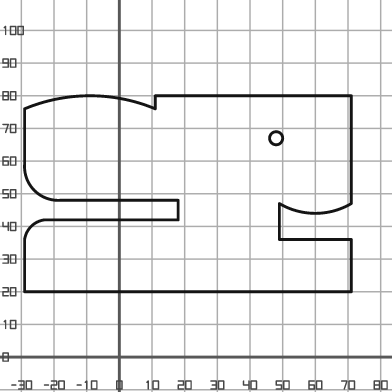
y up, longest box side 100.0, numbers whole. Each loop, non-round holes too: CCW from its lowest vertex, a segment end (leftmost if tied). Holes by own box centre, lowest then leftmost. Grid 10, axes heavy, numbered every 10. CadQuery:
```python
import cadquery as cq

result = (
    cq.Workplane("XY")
    .moveTo(-29.0, 20.0)
    .lineTo(71.0, 20.0)
    .lineTo(71.0, 36.0)
    .lineTo(49.0, 36.0)
    .lineTo(49.0, 47.0)
    .threePointArc((60.0, 44.0), (71.0, 47.0))
    .lineTo(71.0, 80.0)
    .lineTo(11.0, 80.0)
    .lineTo(11.0, 76.0)
    .threePointArc((-9.0, 80.0), (-29.0, 76.0))
    .lineTo(-29.0, 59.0)
    .threePointArc((-26.0, 51.0), (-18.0, 48.0))
    .lineTo(18.0, 48.0)
    .lineTo(18.0, 42.0)
    .lineTo(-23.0, 42.0)
    .threePointArc((-27.0, 40.0), (-29.0, 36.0))
    .close()
    .moveTo(48.0, 67.0)
    .circle(2.0)
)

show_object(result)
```